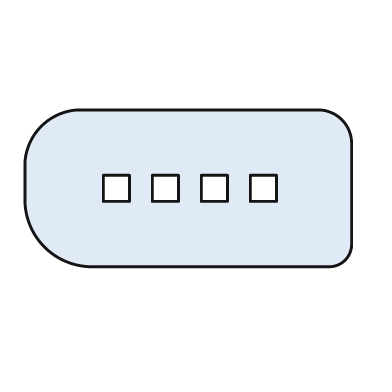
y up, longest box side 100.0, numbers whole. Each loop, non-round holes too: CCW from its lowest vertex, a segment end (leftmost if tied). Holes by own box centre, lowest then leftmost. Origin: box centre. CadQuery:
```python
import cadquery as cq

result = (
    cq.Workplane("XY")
    .moveTo(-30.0, -24.0)
    .lineTo(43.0, -24.0)
    .threePointArc((48.0, -22.0), (50.0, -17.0))
    .lineTo(50.0, 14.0)
    .threePointArc((47.0, 21.0), (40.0, 24.0))
    .lineTo(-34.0, 24.0)
    .threePointArc((-45.0, 19.0), (-50.0, 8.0))
    .lineTo(-50.0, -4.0)
    .threePointArc((-44.0, -18.0), (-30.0, -24.0))
    .close()
    .moveTo(-26.0, -4.0)
    .lineTo(-18.0, -4.0)
    .lineTo(-18.0, 4.0)
    .lineTo(-26.0, 4.0)
    .close()
    .moveTo(-11.0, -4.0)
    .lineTo(-3.0, -4.0)
    .lineTo(-3.0, 4.0)
    .lineTo(-11.0, 4.0)
    .close()
    .moveTo(4.0, -4.0)
    .lineTo(12.0, -4.0)
    .lineTo(12.0, 4.0)
    .lineTo(4.0, 4.0)
    .close()
    .moveTo(19.0, -4.0)
    .lineTo(27.0, -4.0)
    .lineTo(27.0, 4.0)
    .lineTo(19.0, 4.0)
    .close()
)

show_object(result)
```